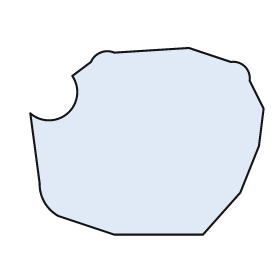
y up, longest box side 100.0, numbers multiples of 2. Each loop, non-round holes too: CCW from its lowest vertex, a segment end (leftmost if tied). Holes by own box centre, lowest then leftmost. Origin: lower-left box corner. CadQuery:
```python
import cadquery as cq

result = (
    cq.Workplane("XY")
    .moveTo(36.0, 0.0)
    .lineTo(74.0, 0.0)
    .lineTo(90.0, 18.0)
    .lineTo(98.0, 38.0)
    .lineTo(100.0, 54.0)
    .lineTo(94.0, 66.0)
    .threePointArc((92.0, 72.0), (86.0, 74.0))
    .lineTo(68.0, 80.0)
    .lineTo(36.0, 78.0)
    .threePointArc((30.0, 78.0), (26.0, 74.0))
    .lineTo(18.0, 68.0)
    .threePointArc((16.0, 52.0), (0.0, 52.0))
    .lineTo(4.0, 22.0)
    .threePointArc((6.0, 14.0), (12.0, 8.0))
    .close()
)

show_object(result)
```